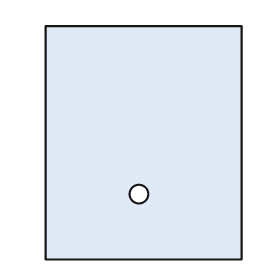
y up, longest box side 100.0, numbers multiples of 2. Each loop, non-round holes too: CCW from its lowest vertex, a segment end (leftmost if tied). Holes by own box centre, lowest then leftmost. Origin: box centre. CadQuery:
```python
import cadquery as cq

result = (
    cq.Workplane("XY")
    .moveTo(-42.0, -50.0)
    .lineTo(42.0, -50.0)
    .lineTo(42.0, 50.0)
    .lineTo(-42.0, 50.0)
    .close()
    .moveTo(-2.0, -22.0)
    .circle(4.0)
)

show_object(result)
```